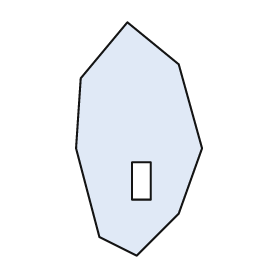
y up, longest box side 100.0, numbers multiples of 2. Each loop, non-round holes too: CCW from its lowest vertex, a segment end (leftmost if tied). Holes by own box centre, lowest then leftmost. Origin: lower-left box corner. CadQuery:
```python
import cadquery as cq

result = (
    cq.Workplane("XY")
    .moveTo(26.0, 0.0)
    .lineTo(44.0, 18.0)
    .lineTo(54.0, 46.0)
    .lineTo(44.0, 82.0)
    .lineTo(22.0, 100.0)
    .lineTo(2.0, 76.0)
    .lineTo(0.0, 46.0)
    .lineTo(10.0, 8.0)
    .close()
    .moveTo(24.0, 24.0)
    .lineTo(32.0, 24.0)
    .lineTo(32.0, 40.0)
    .lineTo(24.0, 40.0)
    .close()
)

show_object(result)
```